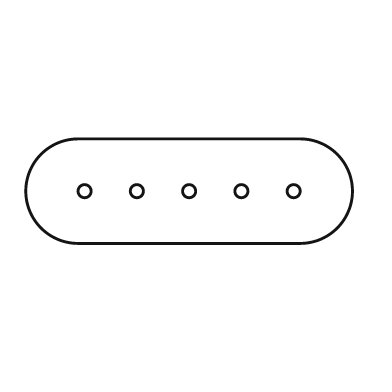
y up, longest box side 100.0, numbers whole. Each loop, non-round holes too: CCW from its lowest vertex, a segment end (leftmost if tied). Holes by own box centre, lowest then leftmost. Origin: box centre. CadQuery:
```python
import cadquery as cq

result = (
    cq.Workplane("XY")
    .moveTo(-34.0, -16.0)
    .lineTo(34.0, -16.0)
    .threePointArc((50.0, 0.0), (34.0, 16.0))
    .lineTo(-34.0, 16.0)
    .threePointArc((-50.0, 0.0), (-34.0, -16.0))
    .close()
    .moveTo(-32.0, 0.0)
    .circle(2.0)
    .moveTo(-16.0, 0.0)
    .circle(2.0)
    .moveTo(0.0, 0.0)
    .circle(2.0)
    .moveTo(16.0, 0.0)
    .circle(2.0)
    .moveTo(32.0, 0.0)
    .circle(2.0)
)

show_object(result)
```